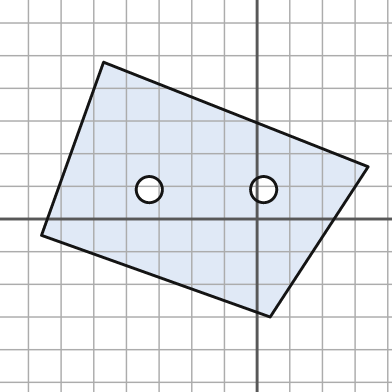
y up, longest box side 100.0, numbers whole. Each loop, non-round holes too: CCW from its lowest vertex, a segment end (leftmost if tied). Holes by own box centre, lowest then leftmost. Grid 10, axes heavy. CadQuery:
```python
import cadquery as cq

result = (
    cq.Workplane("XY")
    .moveTo(4.0, -30.0)
    .lineTo(34.0, 16.0)
    .lineTo(-47.0, 48.0)
    .lineTo(-66.0, -5.0)
    .close()
    .moveTo(-33.0, 9.0)
    .circle(4.0)
    .moveTo(2.0, 9.0)
    .circle(4.0)
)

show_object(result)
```